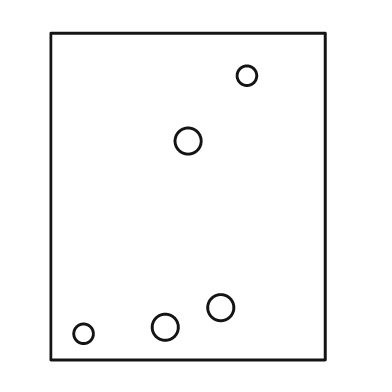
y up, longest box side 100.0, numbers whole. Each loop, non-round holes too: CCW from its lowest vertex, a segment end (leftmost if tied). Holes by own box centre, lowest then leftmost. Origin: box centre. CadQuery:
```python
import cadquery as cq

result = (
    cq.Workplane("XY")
    .moveTo(-42.0, -50.0)
    .lineTo(42.0, -50.0)
    .lineTo(42.0, 50.0)
    .lineTo(-42.0, 50.0)
    .close()
    .moveTo(-32.0, -42.0)
    .circle(3.0)
    .moveTo(-7.0, -40.0)
    .circle(4.0)
    .moveTo(10.0, -34.0)
    .circle(4.0)
    .moveTo(0.0, 17.0)
    .circle(4.0)
    .moveTo(18.0, 37.0)
    .circle(3.0)
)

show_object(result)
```